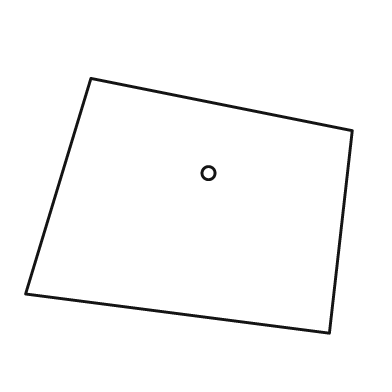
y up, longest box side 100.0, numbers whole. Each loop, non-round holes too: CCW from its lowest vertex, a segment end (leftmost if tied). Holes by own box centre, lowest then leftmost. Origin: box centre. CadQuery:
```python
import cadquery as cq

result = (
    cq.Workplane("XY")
    .moveTo(43.0, -39.0)
    .lineTo(50.0, 23.0)
    .lineTo(-30.0, 39.0)
    .lineTo(-50.0, -27.0)
    .close()
    .moveTo(6.0, 10.0)
    .circle(2.0)
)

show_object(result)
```